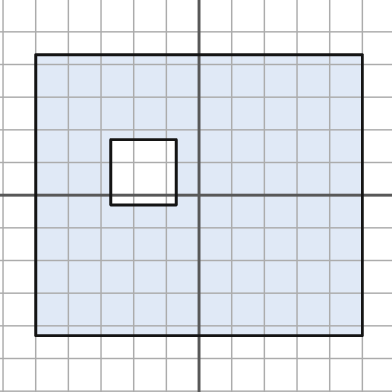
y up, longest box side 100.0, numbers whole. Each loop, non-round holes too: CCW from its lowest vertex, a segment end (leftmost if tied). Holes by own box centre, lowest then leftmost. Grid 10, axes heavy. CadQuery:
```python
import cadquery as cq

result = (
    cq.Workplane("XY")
    .moveTo(-50.0, -43.0)
    .lineTo(50.0, -43.0)
    .lineTo(50.0, 43.0)
    .lineTo(-50.0, 43.0)
    .close()
    .moveTo(-27.0, -3.0)
    .lineTo(-7.0, -3.0)
    .lineTo(-7.0, 17.0)
    .lineTo(-27.0, 17.0)
    .close()
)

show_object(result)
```